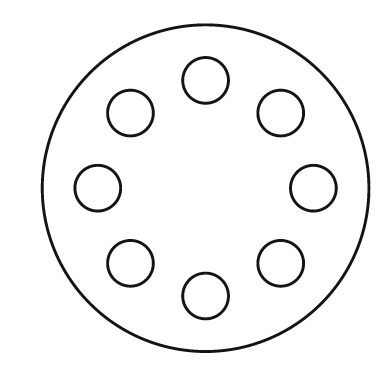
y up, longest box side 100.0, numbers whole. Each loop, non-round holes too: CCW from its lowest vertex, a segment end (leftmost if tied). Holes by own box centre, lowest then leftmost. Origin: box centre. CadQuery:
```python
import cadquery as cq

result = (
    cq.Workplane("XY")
    .moveTo(0.0, 0.0)
    .circle(50.0)
    .moveTo(0.0, -33.0)
    .circle(7.0)
    .moveTo(-23.0, -23.0)
    .circle(7.0)
    .moveTo(23.0, -23.0)
    .circle(7.0)
    .moveTo(-33.0, 0.0)
    .circle(7.0)
    .moveTo(33.0, 0.0)
    .circle(7.0)
    .moveTo(-23.0, 23.0)
    .circle(7.0)
    .moveTo(23.0, 23.0)
    .circle(7.0)
    .moveTo(0.0, 33.0)
    .circle(7.0)
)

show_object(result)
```